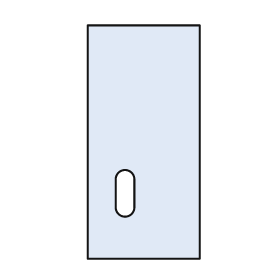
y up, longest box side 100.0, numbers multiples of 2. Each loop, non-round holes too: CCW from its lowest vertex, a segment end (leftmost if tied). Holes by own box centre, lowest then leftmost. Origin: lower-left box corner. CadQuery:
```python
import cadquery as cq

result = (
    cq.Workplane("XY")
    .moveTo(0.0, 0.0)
    .lineTo(48.0, 0.0)
    .lineTo(48.0, 100.0)
    .lineTo(0.0, 100.0)
    .close()
    .moveTo(12.0, 22.0)
    .threePointArc((16.0, 18.0), (20.0, 22.0))
    .lineTo(20.0, 34.0)
    .threePointArc((16.0, 38.0), (12.0, 34.0))
    .close()
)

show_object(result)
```